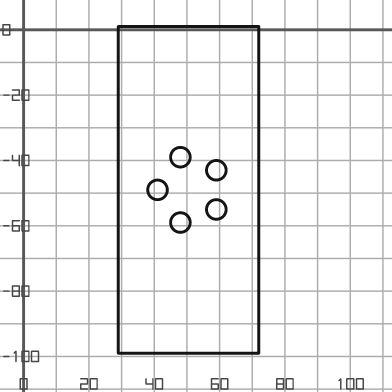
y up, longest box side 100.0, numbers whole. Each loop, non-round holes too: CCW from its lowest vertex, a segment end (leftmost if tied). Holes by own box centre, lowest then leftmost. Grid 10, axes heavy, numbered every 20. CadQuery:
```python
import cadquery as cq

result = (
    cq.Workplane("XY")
    .moveTo(29.0, -99.0)
    .lineTo(72.0, -99.0)
    .lineTo(72.0, 1.0)
    .lineTo(29.0, 1.0)
    .close()
    .moveTo(48.0, -59.0)
    .circle(3.0)
    .moveTo(59.0, -55.0)
    .circle(3.0)
    .moveTo(41.0, -49.0)
    .circle(3.0)
    .moveTo(59.0, -43.0)
    .circle(3.0)
    .moveTo(48.0, -39.0)
    .circle(3.0)
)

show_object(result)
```